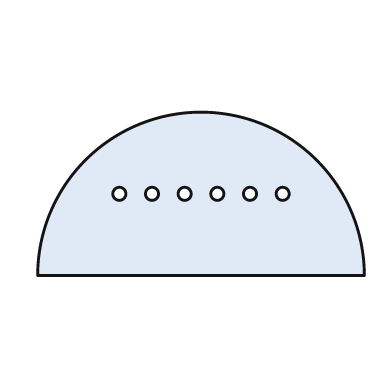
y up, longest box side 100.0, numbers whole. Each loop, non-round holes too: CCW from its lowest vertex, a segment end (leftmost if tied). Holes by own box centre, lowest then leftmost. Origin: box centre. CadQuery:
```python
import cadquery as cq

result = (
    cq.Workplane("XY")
    .moveTo(-50.0, -25.0)
    .lineTo(50.0, -25.0)
    .threePointArc((0.0, 25.0), (-50.0, -25.0))
    .close()
    .moveTo(-25.0, 0.0)
    .circle(2.0)
    .moveTo(-15.0, 0.0)
    .circle(2.0)
    .moveTo(-5.0, 0.0)
    .circle(2.0)
    .moveTo(5.0, 0.0)
    .circle(2.0)
    .moveTo(15.0, 0.0)
    .circle(2.0)
    .moveTo(25.0, 0.0)
    .circle(2.0)
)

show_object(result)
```